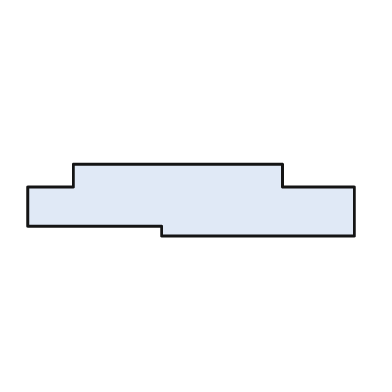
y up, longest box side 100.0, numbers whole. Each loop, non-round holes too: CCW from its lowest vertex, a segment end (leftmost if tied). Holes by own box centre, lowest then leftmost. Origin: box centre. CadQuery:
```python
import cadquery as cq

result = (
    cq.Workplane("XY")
    .moveTo(-9.0, -11.0)
    .lineTo(50.0, -11.0)
    .lineTo(50.0, 4.0)
    .lineTo(28.0, 4.0)
    .lineTo(28.0, 11.0)
    .lineTo(-36.0, 11.0)
    .lineTo(-36.0, 4.0)
    .lineTo(-50.0, 4.0)
    .lineTo(-50.0, -8.0)
    .lineTo(-9.0, -8.0)
    .close()
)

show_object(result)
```